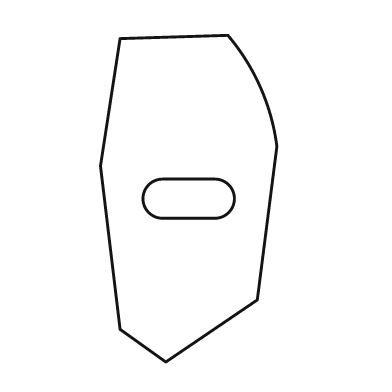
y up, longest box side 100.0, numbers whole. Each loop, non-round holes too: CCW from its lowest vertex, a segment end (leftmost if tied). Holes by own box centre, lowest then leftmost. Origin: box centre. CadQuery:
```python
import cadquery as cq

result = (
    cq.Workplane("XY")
    .moveTo(-7.0, -50.0)
    .lineTo(21.0, -31.0)
    .lineTo(27.0, 16.0)
    .threePointArc((22.0, 34.0), (12.0, 50.0))
    .lineTo(-21.0, 49.0)
    .lineTo(-27.0, 10.0)
    .lineTo(-21.0, -40.0)
    .close()
    .moveTo(-8.0, -6.0)
    .lineTo(8.0, -6.0)
    .threePointArc((14.0, 0.0), (8.0, 6.0))
    .lineTo(-8.0, 6.0)
    .threePointArc((-14.0, 0.0), (-8.0, -6.0))
    .close()
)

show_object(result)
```